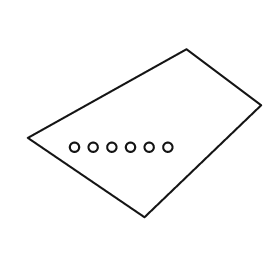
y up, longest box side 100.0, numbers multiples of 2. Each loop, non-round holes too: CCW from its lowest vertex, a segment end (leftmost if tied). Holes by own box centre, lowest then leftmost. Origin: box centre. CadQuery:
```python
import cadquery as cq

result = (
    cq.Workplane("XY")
    .moveTo(0.0, -36.0)
    .lineTo(50.0, 12.0)
    .lineTo(18.0, 36.0)
    .lineTo(-50.0, -2.0)
    .close()
    .moveTo(-30.0, -6.0)
    .circle(2.0)
    .moveTo(-22.0, -6.0)
    .circle(2.0)
    .moveTo(-14.0, -6.0)
    .circle(2.0)
    .moveTo(-6.0, -6.0)
    .circle(2.0)
    .moveTo(2.0, -6.0)
    .circle(2.0)
    .moveTo(10.0, -6.0)
    .circle(2.0)
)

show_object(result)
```